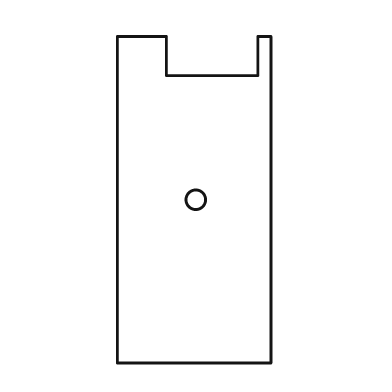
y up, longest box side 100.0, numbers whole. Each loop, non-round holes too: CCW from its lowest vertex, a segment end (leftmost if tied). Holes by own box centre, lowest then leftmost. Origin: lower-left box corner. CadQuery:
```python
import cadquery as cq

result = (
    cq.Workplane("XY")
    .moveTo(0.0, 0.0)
    .lineTo(47.0, 0.0)
    .lineTo(47.0, 100.0)
    .lineTo(43.0, 100.0)
    .lineTo(43.0, 88.0)
    .lineTo(15.0, 88.0)
    .lineTo(15.0, 100.0)
    .lineTo(0.0, 100.0)
    .close()
    .moveTo(24.0, 50.0)
    .circle(3.0)
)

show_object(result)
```